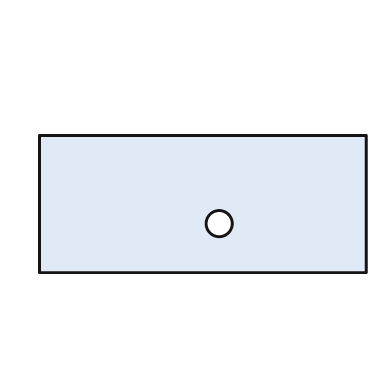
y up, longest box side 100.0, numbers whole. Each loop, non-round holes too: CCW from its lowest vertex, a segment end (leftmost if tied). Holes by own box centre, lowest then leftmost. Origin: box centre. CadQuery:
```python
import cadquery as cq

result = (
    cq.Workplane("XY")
    .moveTo(-50.0, -21.0)
    .lineTo(50.0, -21.0)
    .lineTo(50.0, 21.0)
    .lineTo(-50.0, 21.0)
    .close()
    .moveTo(5.0, -6.0)
    .circle(4.0)
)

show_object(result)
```